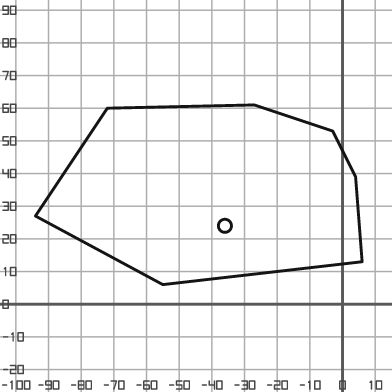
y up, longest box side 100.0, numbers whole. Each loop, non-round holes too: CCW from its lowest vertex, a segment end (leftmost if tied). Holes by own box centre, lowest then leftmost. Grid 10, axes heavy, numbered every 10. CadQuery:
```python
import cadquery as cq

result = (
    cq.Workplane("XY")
    .moveTo(-55.0, 6.0)
    .lineTo(6.0, 13.0)
    .lineTo(4.0, 39.0)
    .lineTo(-3.0, 53.0)
    .lineTo(-27.0, 61.0)
    .lineTo(-72.0, 60.0)
    .lineTo(-94.0, 27.0)
    .close()
    .moveTo(-36.0, 24.0)
    .circle(2.0)
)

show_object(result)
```